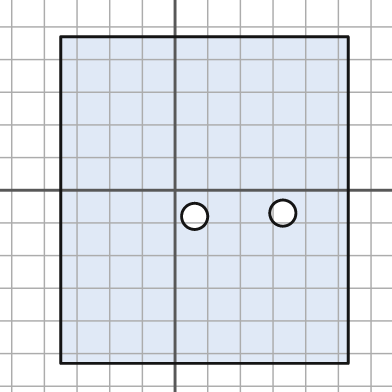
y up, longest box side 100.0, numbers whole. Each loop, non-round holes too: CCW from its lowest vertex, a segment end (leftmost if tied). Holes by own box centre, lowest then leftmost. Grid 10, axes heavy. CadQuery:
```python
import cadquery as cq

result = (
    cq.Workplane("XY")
    .moveTo(-35.0, -53.0)
    .lineTo(53.0, -53.0)
    .lineTo(53.0, 47.0)
    .lineTo(-35.0, 47.0)
    .close()
    .moveTo(6.0, -8.0)
    .circle(4.0)
    .moveTo(33.0, -7.0)
    .circle(4.0)
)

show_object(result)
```